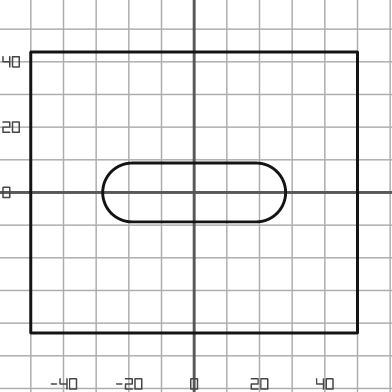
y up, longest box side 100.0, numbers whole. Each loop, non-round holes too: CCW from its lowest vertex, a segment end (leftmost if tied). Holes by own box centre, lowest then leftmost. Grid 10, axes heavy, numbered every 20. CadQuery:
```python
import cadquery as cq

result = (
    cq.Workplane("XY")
    .moveTo(-50.0, -43.0)
    .lineTo(50.0, -43.0)
    .lineTo(50.0, 43.0)
    .lineTo(-50.0, 43.0)
    .close()
    .moveTo(-19.0, -9.0)
    .lineTo(19.0, -9.0)
    .threePointArc((28.0, 0.0), (19.0, 9.0))
    .lineTo(-19.0, 9.0)
    .threePointArc((-28.0, 0.0), (-19.0, -9.0))
    .close()
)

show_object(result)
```